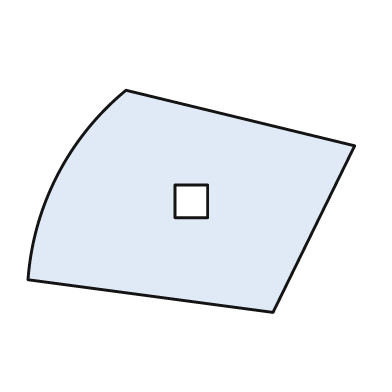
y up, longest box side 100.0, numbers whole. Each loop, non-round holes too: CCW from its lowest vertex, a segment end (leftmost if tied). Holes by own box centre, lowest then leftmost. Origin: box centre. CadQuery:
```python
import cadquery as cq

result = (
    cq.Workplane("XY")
    .moveTo(25.0, -34.0)
    .lineTo(50.0, 17.0)
    .lineTo(-20.0, 34.0)
    .threePointArc((-41.0, 8.0), (-50.0, -24.0))
    .close()
    .moveTo(-5.0, -5.0)
    .lineTo(5.0, -5.0)
    .lineTo(5.0, 5.0)
    .lineTo(-5.0, 5.0)
    .close()
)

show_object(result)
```